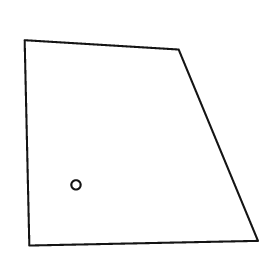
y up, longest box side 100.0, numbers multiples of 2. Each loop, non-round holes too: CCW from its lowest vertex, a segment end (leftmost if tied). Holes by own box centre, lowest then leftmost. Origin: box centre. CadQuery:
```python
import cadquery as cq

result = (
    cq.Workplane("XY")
    .moveTo(-48.0, -44.0)
    .lineTo(50.0, -42.0)
    .lineTo(16.0, 40.0)
    .lineTo(-50.0, 44.0)
    .close()
    .moveTo(-28.0, -18.0)
    .circle(2.0)
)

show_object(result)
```